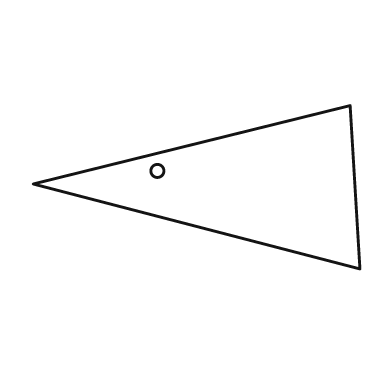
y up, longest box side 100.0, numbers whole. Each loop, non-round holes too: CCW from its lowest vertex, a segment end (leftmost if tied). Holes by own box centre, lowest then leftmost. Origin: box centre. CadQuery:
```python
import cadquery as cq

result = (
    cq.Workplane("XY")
    .moveTo(50.0, -25.0)
    .lineTo(47.0, 25.0)
    .lineTo(-50.0, 1.0)
    .close()
    .moveTo(-12.0, 5.0)
    .circle(2.0)
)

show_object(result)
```